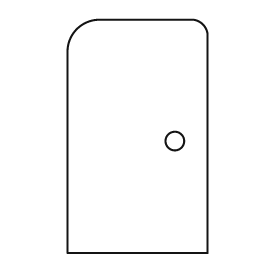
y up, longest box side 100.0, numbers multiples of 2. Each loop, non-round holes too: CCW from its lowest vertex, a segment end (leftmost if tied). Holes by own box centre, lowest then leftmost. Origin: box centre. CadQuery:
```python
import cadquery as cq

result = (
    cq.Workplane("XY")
    .moveTo(-30.0, -50.0)
    .lineTo(30.0, -50.0)
    .lineTo(30.0, 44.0)
    .threePointArc((28.0, 48.0), (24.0, 50.0))
    .lineTo(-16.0, 50.0)
    .threePointArc((-26.0, 46.0), (-30.0, 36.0))
    .close()
    .moveTo(16.0, -2.0)
    .circle(4.0)
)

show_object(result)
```